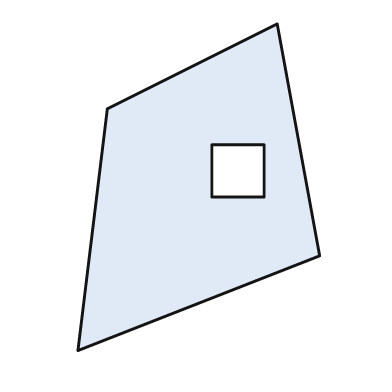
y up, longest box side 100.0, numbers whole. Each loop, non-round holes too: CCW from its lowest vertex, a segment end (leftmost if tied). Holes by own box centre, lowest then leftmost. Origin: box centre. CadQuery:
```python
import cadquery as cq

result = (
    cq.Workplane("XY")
    .moveTo(-37.0, -50.0)
    .lineTo(37.0, -21.0)
    .lineTo(24.0, 50.0)
    .lineTo(-28.0, 24.0)
    .close()
    .moveTo(4.0, -3.0)
    .lineTo(20.0, -3.0)
    .lineTo(20.0, 13.0)
    .lineTo(4.0, 13.0)
    .close()
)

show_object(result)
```